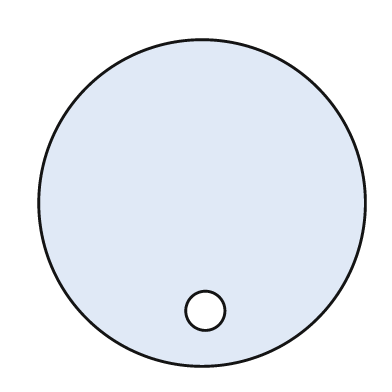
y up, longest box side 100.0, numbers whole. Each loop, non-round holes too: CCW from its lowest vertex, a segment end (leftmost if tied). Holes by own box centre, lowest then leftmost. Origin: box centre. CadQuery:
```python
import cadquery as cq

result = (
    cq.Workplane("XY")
    .moveTo(0.0, 0.0)
    .circle(50.0)
    .moveTo(1.0, -33.0)
    .circle(6.0)
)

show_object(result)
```